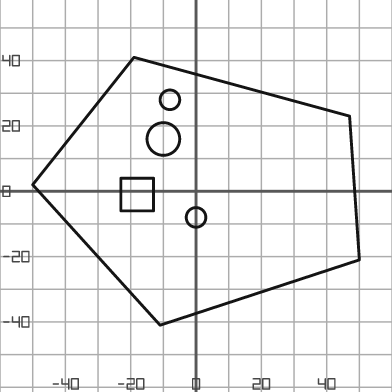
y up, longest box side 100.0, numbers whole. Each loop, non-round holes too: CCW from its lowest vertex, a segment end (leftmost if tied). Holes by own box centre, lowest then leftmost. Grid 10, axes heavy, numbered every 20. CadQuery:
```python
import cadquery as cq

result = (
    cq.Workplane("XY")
    .moveTo(-11.0, -41.0)
    .lineTo(50.0, -21.0)
    .lineTo(47.0, 23.0)
    .lineTo(-19.0, 41.0)
    .lineTo(-50.0, 2.0)
    .close()
    .moveTo(0.0, -8.0)
    .circle(3.0)
    .moveTo(-23.0, -6.0)
    .lineTo(-13.0, -6.0)
    .lineTo(-13.0, 4.0)
    .lineTo(-23.0, 4.0)
    .close()
    .moveTo(-10.0, 16.0)
    .circle(5.0)
    .moveTo(-8.0, 28.0)
    .circle(3.0)
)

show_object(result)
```